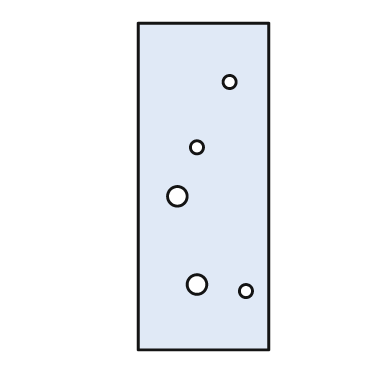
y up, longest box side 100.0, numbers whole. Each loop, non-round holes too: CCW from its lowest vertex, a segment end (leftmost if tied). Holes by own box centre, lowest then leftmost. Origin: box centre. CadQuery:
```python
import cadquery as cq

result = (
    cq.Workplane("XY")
    .moveTo(-20.0, -50.0)
    .lineTo(20.0, -50.0)
    .lineTo(20.0, 50.0)
    .lineTo(-20.0, 50.0)
    .close()
    .moveTo(13.0, -32.0)
    .circle(2.0)
    .moveTo(-2.0, -30.0)
    .circle(3.0)
    .moveTo(-8.0, -3.0)
    .circle(3.0)
    .moveTo(-2.0, 12.0)
    .circle(2.0)
    .moveTo(8.0, 32.0)
    .circle(2.0)
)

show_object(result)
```